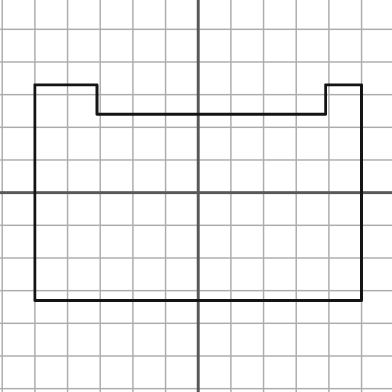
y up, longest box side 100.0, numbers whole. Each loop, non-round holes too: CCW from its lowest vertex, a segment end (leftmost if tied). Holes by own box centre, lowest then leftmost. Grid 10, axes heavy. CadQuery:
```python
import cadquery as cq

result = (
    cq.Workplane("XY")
    .moveTo(-50.0, -33.0)
    .lineTo(50.0, -33.0)
    .lineTo(50.0, 33.0)
    .lineTo(39.0, 33.0)
    .lineTo(39.0, 24.0)
    .lineTo(-31.0, 24.0)
    .lineTo(-31.0, 33.0)
    .lineTo(-50.0, 33.0)
    .close()
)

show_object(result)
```